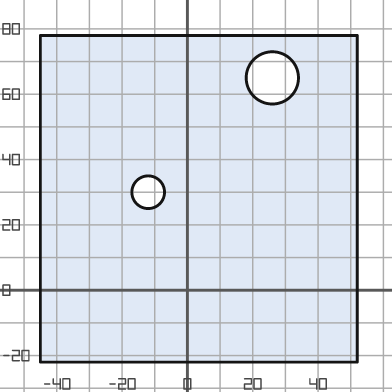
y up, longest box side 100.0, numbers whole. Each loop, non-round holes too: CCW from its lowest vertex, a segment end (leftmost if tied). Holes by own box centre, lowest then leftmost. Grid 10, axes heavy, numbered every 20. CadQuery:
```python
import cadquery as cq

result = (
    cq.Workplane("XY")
    .moveTo(-45.0, -22.0)
    .lineTo(52.0, -22.0)
    .lineTo(52.0, 78.0)
    .lineTo(-45.0, 78.0)
    .close()
    .moveTo(-12.0, 30.0)
    .circle(5.0)
    .moveTo(26.0, 65.0)
    .circle(8.0)
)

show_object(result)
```